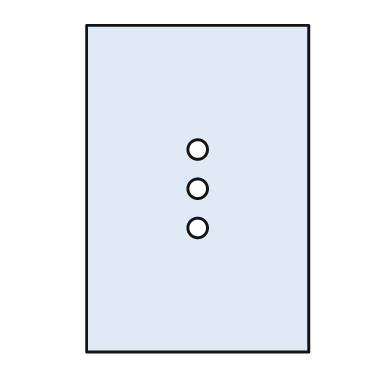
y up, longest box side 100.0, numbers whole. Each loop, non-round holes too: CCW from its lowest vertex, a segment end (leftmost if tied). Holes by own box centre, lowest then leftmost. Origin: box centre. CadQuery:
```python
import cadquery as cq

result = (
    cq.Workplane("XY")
    .moveTo(-34.0, -50.0)
    .lineTo(34.0, -50.0)
    .lineTo(34.0, 50.0)
    .lineTo(-34.0, 50.0)
    .close()
    .moveTo(0.0, -12.0)
    .circle(3.0)
    .moveTo(0.0, 0.0)
    .circle(3.0)
    .moveTo(0.0, 12.0)
    .circle(3.0)
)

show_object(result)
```